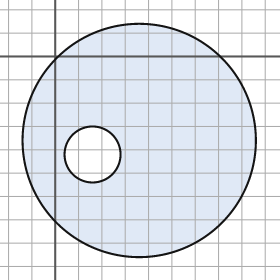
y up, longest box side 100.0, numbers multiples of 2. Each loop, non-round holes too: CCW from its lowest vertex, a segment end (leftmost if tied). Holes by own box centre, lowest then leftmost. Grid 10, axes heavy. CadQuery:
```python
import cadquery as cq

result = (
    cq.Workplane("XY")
    .moveTo(36.0, -36.0)
    .circle(50.0)
    .moveTo(16.0, -42.0)
    .circle(12.0)
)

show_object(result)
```